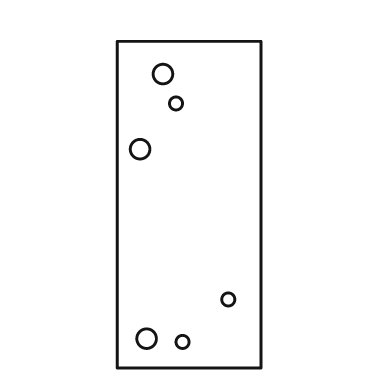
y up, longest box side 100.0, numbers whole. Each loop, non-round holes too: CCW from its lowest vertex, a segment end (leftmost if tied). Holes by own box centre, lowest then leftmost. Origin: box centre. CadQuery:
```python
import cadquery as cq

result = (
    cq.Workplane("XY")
    .moveTo(-22.0, -50.0)
    .lineTo(22.0, -50.0)
    .lineTo(22.0, 50.0)
    .lineTo(-22.0, 50.0)
    .close()
    .moveTo(-2.0, -42.0)
    .circle(2.0)
    .moveTo(-13.0, -41.0)
    .circle(3.0)
    .moveTo(12.0, -29.0)
    .circle(2.0)
    .moveTo(-15.0, 17.0)
    .circle(3.0)
    .moveTo(-4.0, 31.0)
    .circle(2.0)
    .moveTo(-8.0, 40.0)
    .circle(3.0)
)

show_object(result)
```